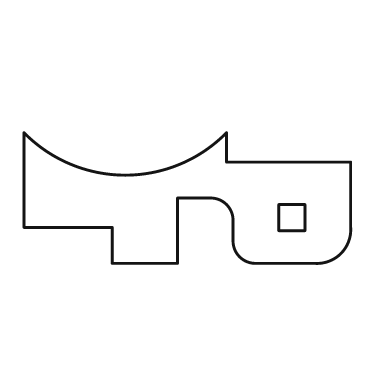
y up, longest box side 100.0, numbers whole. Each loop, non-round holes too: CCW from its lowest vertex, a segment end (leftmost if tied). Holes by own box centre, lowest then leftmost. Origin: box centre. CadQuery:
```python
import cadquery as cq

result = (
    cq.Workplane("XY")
    .moveTo(-23.0, -20.0)
    .lineTo(-3.0, -20.0)
    .lineTo(-3.0, 0.0)
    .lineTo(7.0, 0.0)
    .threePointArc((12.0, -2.0), (14.0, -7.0))
    .lineTo(14.0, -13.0)
    .threePointArc((16.0, -18.0), (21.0, -20.0))
    .lineTo(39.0, -20.0)
    .threePointArc((47.0, -17.0), (50.0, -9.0))
    .lineTo(50.0, 11.0)
    .lineTo(12.0, 11.0)
    .lineTo(12.0, 20.0)
    .threePointArc((-19.0, 7.0), (-50.0, 20.0))
    .lineTo(-50.0, -9.0)
    .lineTo(-23.0, -9.0)
    .close()
    .moveTo(28.0, -10.0)
    .lineTo(36.0, -10.0)
    .lineTo(36.0, -2.0)
    .lineTo(28.0, -2.0)
    .close()
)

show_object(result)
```